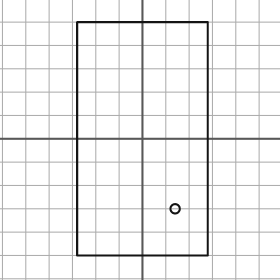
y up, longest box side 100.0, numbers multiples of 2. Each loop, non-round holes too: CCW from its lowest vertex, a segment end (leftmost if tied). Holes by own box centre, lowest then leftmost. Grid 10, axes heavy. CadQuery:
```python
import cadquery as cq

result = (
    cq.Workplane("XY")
    .moveTo(-28.0, -50.0)
    .lineTo(28.0, -50.0)
    .lineTo(28.0, 50.0)
    .lineTo(-28.0, 50.0)
    .close()
    .moveTo(14.0, -30.0)
    .circle(2.0)
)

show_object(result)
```